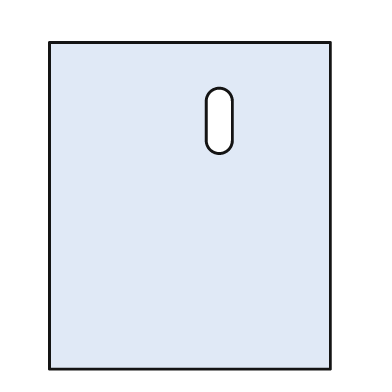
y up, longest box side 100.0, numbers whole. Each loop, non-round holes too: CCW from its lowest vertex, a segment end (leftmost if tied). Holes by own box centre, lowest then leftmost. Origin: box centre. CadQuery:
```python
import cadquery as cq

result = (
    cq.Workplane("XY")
    .moveTo(-43.0, -50.0)
    .lineTo(43.0, -50.0)
    .lineTo(43.0, 50.0)
    .lineTo(-43.0, 50.0)
    .close()
    .moveTo(5.0, 20.0)
    .threePointArc((9.0, 16.0), (13.0, 20.0))
    .lineTo(13.0, 32.0)
    .threePointArc((9.0, 36.0), (5.0, 32.0))
    .close()
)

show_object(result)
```